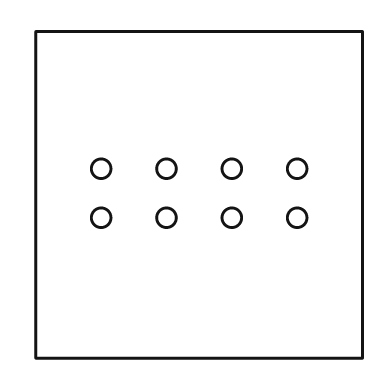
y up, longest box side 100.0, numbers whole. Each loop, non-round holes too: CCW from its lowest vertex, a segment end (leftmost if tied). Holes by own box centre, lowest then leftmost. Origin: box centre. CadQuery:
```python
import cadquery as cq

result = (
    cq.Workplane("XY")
    .moveTo(-50.0, -50.0)
    .lineTo(50.0, -50.0)
    .lineTo(50.0, 50.0)
    .lineTo(-50.0, 50.0)
    .close()
    .moveTo(-30.0, -7.0)
    .circle(3.0)
    .moveTo(-10.0, -7.0)
    .circle(3.0)
    .moveTo(10.0, -7.0)
    .circle(3.0)
    .moveTo(30.0, -7.0)
    .circle(3.0)
    .moveTo(-30.0, 8.0)
    .circle(3.0)
    .moveTo(-10.0, 8.0)
    .circle(3.0)
    .moveTo(10.0, 8.0)
    .circle(3.0)
    .moveTo(30.0, 8.0)
    .circle(3.0)
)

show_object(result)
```